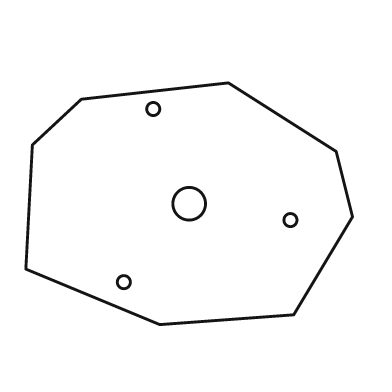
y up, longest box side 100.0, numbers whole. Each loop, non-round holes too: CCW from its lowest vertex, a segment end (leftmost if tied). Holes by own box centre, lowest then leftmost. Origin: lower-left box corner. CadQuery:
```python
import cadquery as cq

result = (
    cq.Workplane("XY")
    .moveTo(41.0, 0.0)
    .lineTo(82.0, 3.0)
    .lineTo(100.0, 33.0)
    .lineTo(95.0, 53.0)
    .lineTo(62.0, 74.0)
    .lineTo(17.0, 69.0)
    .lineTo(2.0, 55.0)
    .lineTo(0.0, 17.0)
    .close()
    .moveTo(30.0, 13.0)
    .circle(2.0)
    .moveTo(81.0, 32.0)
    .circle(2.0)
    .moveTo(50.0, 37.0)
    .circle(5.0)
    .moveTo(39.0, 66.0)
    .circle(2.0)
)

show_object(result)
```